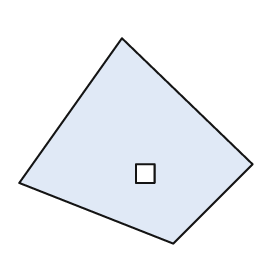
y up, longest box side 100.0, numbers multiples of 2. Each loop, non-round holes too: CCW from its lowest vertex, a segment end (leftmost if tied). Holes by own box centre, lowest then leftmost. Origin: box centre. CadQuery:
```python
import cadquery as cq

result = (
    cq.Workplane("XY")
    .moveTo(16.0, -44.0)
    .lineTo(50.0, -10.0)
    .lineTo(-6.0, 44.0)
    .lineTo(-50.0, -18.0)
    .close()
    .moveTo(0.0, -18.0)
    .lineTo(8.0, -18.0)
    .lineTo(8.0, -10.0)
    .lineTo(0.0, -10.0)
    .close()
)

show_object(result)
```